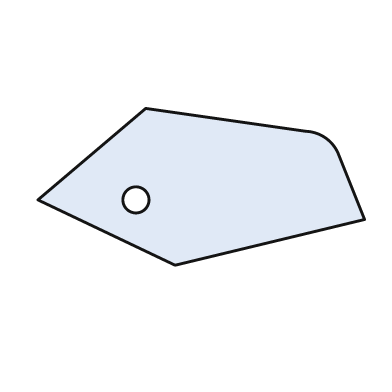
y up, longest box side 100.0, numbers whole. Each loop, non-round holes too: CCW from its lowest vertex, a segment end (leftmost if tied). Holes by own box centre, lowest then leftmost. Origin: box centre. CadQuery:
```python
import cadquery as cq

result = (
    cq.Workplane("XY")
    .moveTo(-8.0, -24.0)
    .lineTo(50.0, -10.0)
    .lineTo(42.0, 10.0)
    .threePointArc((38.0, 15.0), (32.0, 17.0))
    .lineTo(-17.0, 24.0)
    .lineTo(-50.0, -4.0)
    .close()
    .moveTo(-20.0, -4.0)
    .circle(4.0)
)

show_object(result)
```